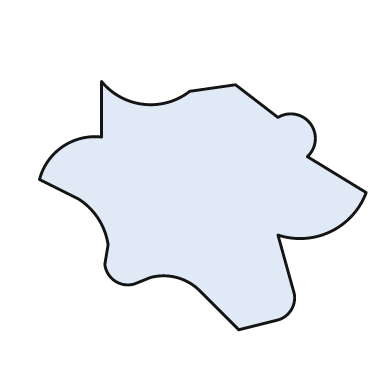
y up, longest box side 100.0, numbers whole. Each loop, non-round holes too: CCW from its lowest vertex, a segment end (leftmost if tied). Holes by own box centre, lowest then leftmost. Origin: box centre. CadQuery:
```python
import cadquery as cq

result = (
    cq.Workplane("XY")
    .moveTo(11.0, -38.0)
    .lineTo(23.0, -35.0)
    .threePointArc((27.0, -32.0), (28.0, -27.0))
    .lineTo(23.0, -9.0)
    .threePointArc((39.0, -8.0), (50.0, 4.0))
    .lineTo(32.0, 15.0)
    .threePointArc((33.0, 25.0), (23.0, 27.0))
    .lineTo(10.0, 37.0)
    .lineTo(-4.0, 35.0)
    .threePointArc((-18.0, 31.0), (-31.0, 38.0))
    .lineTo(-31.0, 21.0)
    .threePointArc((-43.0, 18.0), (-50.0, 8.0))
    .lineTo(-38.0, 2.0)
    .threePointArc((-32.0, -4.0), (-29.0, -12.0))
    .lineTo(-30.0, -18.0)
    .threePointArc((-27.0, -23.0), (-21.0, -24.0))
    .lineTo(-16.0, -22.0)
    .threePointArc((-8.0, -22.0), (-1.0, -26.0))
    .close()
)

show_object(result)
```